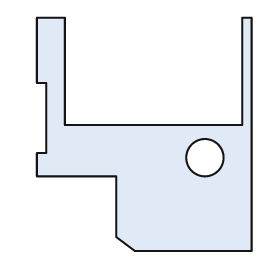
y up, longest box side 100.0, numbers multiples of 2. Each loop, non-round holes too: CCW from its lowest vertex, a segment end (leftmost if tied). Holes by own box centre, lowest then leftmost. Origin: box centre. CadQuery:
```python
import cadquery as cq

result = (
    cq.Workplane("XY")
    .moveTo(-4.0, -50.0)
    .lineTo(46.0, -50.0)
    .lineTo(46.0, 50.0)
    .lineTo(42.0, 50.0)
    .lineTo(42.0, 4.0)
    .lineTo(-34.0, 4.0)
    .lineTo(-34.0, 50.0)
    .lineTo(-46.0, 50.0)
    .lineTo(-46.0, 22.0)
    .lineTo(-42.0, 22.0)
    .lineTo(-42.0, -8.0)
    .lineTo(-46.0, -8.0)
    .lineTo(-46.0, -18.0)
    .lineTo(-12.0, -18.0)
    .lineTo(-12.0, -44.0)
    .close()
    .moveTo(26.0, -10.0)
    .circle(8.0)
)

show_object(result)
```